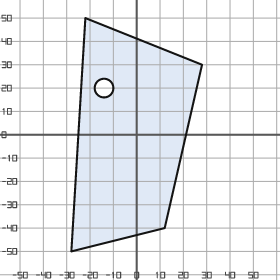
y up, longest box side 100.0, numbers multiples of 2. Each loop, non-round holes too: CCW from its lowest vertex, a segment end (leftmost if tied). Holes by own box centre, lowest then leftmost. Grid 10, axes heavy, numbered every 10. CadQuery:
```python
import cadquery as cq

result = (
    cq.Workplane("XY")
    .moveTo(-28.0, -50.0)
    .lineTo(12.0, -40.0)
    .lineTo(28.0, 30.0)
    .lineTo(-22.0, 50.0)
    .close()
    .moveTo(-14.0, 20.0)
    .circle(4.0)
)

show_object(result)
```